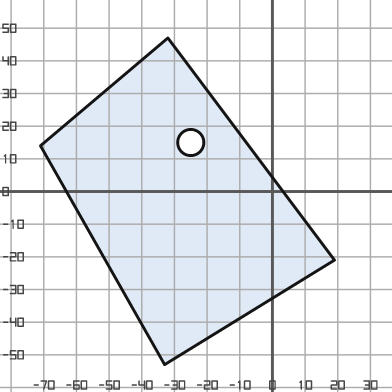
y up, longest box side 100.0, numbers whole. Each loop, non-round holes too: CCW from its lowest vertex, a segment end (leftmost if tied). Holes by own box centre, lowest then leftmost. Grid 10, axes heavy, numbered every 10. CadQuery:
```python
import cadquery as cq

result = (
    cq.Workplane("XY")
    .moveTo(-33.0, -53.0)
    .lineTo(19.0, -21.0)
    .lineTo(-32.0, 47.0)
    .lineTo(-71.0, 14.0)
    .close()
    .moveTo(-25.0, 15.0)
    .circle(4.0)
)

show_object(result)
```